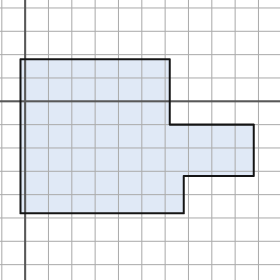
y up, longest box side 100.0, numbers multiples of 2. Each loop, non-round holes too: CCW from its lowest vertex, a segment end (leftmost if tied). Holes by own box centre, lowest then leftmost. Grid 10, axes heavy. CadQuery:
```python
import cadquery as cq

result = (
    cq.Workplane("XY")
    .moveTo(-2.0, -48.0)
    .lineTo(68.0, -48.0)
    .lineTo(68.0, -32.0)
    .lineTo(98.0, -32.0)
    .lineTo(98.0, -10.0)
    .lineTo(62.0, -10.0)
    .lineTo(62.0, 18.0)
    .lineTo(-2.0, 18.0)
    .close()
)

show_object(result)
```